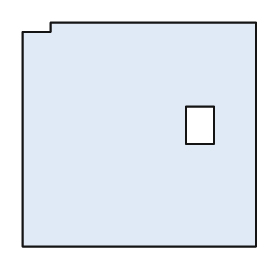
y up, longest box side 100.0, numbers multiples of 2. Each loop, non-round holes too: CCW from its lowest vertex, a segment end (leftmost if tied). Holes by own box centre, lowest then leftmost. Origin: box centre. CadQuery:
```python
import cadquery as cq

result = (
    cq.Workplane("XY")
    .moveTo(-50.0, -48.0)
    .lineTo(50.0, -48.0)
    .lineTo(50.0, 48.0)
    .lineTo(-38.0, 48.0)
    .lineTo(-38.0, 44.0)
    .lineTo(-50.0, 44.0)
    .close()
    .moveTo(20.0, -4.0)
    .lineTo(32.0, -4.0)
    .lineTo(32.0, 12.0)
    .lineTo(20.0, 12.0)
    .close()
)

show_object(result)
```